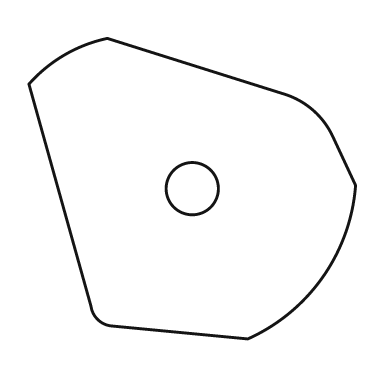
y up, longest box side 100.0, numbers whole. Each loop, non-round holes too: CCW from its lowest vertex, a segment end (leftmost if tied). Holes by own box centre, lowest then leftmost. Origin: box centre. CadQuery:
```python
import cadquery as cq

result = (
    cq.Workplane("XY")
    .moveTo(17.0, -46.0)
    .threePointArc((40.0, -27.0), (50.0, 1.0))
    .lineTo(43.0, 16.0)
    .threePointArc((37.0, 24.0), (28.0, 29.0))
    .lineTo(-26.0, 46.0)
    .threePointArc((-39.0, 41.0), (-50.0, 32.0))
    .lineTo(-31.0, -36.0)
    .threePointArc((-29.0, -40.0), (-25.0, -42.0))
    .close()
    .moveTo(0.0, 0.0)
    .circle(8.0)
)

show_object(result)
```